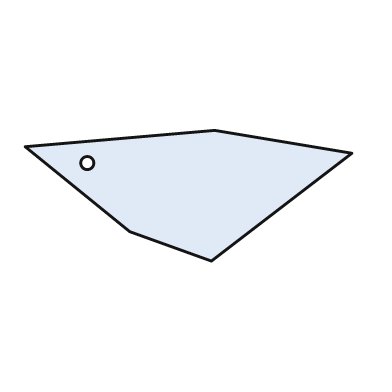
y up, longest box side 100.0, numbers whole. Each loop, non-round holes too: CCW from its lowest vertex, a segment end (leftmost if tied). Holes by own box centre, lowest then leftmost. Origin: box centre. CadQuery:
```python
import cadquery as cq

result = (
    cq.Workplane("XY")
    .moveTo(7.0, -20.0)
    .lineTo(50.0, 13.0)
    .lineTo(8.0, 20.0)
    .lineTo(-50.0, 15.0)
    .lineTo(-18.0, -11.0)
    .close()
    .moveTo(-31.0, 10.0)
    .circle(2.0)
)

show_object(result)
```